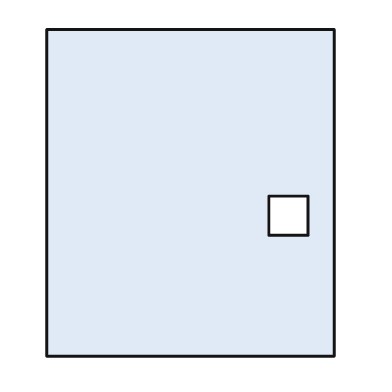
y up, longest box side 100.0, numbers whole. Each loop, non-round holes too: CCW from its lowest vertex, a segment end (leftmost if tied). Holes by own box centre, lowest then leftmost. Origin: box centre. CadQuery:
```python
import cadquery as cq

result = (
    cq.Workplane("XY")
    .moveTo(-44.0, -50.0)
    .lineTo(44.0, -50.0)
    .lineTo(44.0, 50.0)
    .lineTo(-44.0, 50.0)
    .close()
    .moveTo(24.0, -13.0)
    .lineTo(36.0, -13.0)
    .lineTo(36.0, -1.0)
    .lineTo(24.0, -1.0)
    .close()
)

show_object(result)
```